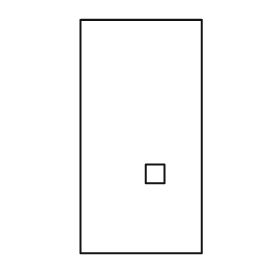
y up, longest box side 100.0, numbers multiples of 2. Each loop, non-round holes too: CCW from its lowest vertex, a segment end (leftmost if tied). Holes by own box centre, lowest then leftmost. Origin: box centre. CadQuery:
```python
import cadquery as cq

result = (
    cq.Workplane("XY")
    .moveTo(-26.0, -50.0)
    .lineTo(26.0, -50.0)
    .lineTo(26.0, 50.0)
    .lineTo(-26.0, 50.0)
    .close()
    .moveTo(2.0, -20.0)
    .lineTo(10.0, -20.0)
    .lineTo(10.0, -12.0)
    .lineTo(2.0, -12.0)
    .close()
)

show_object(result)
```